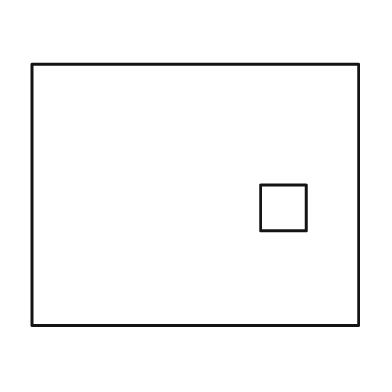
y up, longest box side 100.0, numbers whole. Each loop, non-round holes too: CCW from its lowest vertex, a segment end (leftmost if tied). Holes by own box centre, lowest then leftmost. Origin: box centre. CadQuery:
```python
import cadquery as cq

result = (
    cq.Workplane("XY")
    .moveTo(-50.0, -40.0)
    .lineTo(50.0, -40.0)
    .lineTo(50.0, 40.0)
    .lineTo(-50.0, 40.0)
    .close()
    .moveTo(20.0, -11.0)
    .lineTo(34.0, -11.0)
    .lineTo(34.0, 3.0)
    .lineTo(20.0, 3.0)
    .close()
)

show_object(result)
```